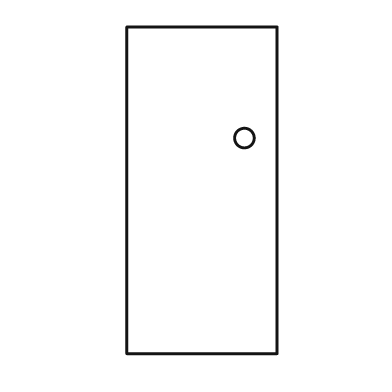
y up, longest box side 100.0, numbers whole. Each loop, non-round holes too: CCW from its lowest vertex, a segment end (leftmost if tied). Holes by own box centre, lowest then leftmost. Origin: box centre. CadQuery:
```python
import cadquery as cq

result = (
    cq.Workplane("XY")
    .moveTo(-23.0, -50.0)
    .lineTo(23.0, -50.0)
    .lineTo(23.0, 50.0)
    .lineTo(-23.0, 50.0)
    .close()
    .moveTo(13.0, 16.0)
    .circle(3.0)
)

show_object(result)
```